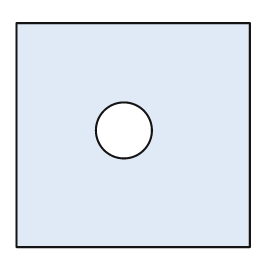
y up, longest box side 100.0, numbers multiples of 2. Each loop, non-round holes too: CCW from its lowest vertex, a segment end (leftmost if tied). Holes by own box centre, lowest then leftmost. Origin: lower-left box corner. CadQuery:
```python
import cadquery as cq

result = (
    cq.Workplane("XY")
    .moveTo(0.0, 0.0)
    .lineTo(100.0, 0.0)
    .lineTo(100.0, 96.0)
    .lineTo(0.0, 96.0)
    .close()
    .moveTo(46.0, 50.0)
    .circle(12.0)
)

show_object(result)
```